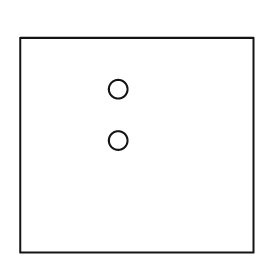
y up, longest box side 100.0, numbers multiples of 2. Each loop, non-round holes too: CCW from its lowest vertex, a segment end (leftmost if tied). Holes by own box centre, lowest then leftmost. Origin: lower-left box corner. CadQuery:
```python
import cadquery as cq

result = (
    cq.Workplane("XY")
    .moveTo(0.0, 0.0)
    .lineTo(100.0, 0.0)
    .lineTo(100.0, 92.0)
    .lineTo(0.0, 92.0)
    .close()
    .moveTo(42.0, 48.0)
    .circle(4.0)
    .moveTo(42.0, 70.0)
    .circle(4.0)
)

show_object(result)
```